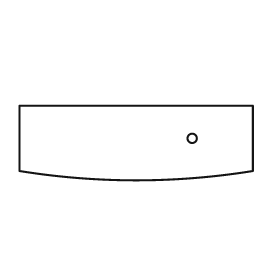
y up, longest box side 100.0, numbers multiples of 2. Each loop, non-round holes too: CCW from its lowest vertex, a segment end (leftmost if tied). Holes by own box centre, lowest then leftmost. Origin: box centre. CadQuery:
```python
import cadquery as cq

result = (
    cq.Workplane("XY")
    .moveTo(-50.0, -12.0)
    .threePointArc((0.0, -16.0), (50.0, -12.0))
    .lineTo(50.0, 16.0)
    .lineTo(-50.0, 16.0)
    .close()
    .moveTo(24.0, 2.0)
    .circle(2.0)
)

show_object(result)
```